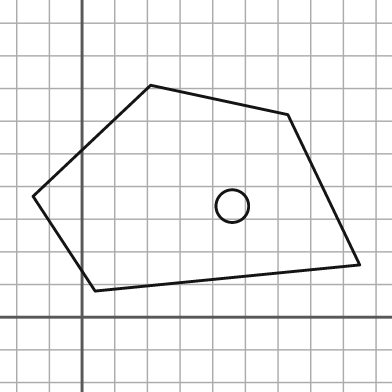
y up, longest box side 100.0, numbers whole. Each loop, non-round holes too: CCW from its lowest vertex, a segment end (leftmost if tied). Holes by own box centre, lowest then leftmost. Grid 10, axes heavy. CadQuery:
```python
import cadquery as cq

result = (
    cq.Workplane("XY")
    .moveTo(4.0, 8.0)
    .lineTo(85.0, 16.0)
    .lineTo(63.0, 62.0)
    .lineTo(21.0, 71.0)
    .lineTo(-15.0, 37.0)
    .close()
    .moveTo(46.0, 34.0)
    .circle(5.0)
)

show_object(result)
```